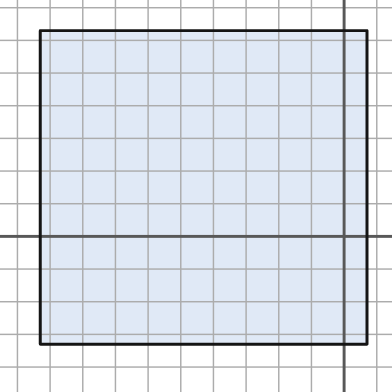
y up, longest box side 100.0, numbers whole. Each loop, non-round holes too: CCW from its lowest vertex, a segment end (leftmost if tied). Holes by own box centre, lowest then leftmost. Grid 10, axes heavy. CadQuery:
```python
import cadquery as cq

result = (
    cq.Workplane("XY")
    .moveTo(-93.0, -33.0)
    .lineTo(7.0, -33.0)
    .lineTo(7.0, 63.0)
    .lineTo(-93.0, 63.0)
    .close()
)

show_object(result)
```